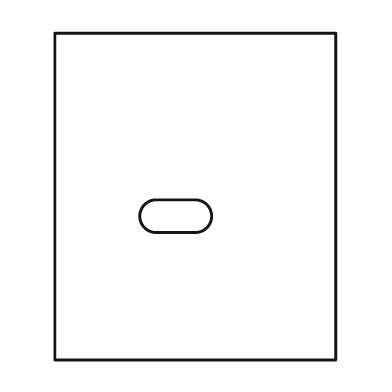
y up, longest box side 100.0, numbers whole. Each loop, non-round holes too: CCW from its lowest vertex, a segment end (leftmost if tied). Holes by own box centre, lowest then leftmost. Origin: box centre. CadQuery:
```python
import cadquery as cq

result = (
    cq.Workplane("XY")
    .moveTo(-43.0, -50.0)
    .lineTo(43.0, -50.0)
    .lineTo(43.0, 50.0)
    .lineTo(-43.0, 50.0)
    .close()
    .moveTo(-12.0, -11.0)
    .lineTo(0.0, -11.0)
    .threePointArc((5.0, -6.0), (0.0, -1.0))
    .lineTo(-12.0, -1.0)
    .threePointArc((-17.0, -6.0), (-12.0, -11.0))
    .close()
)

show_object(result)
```